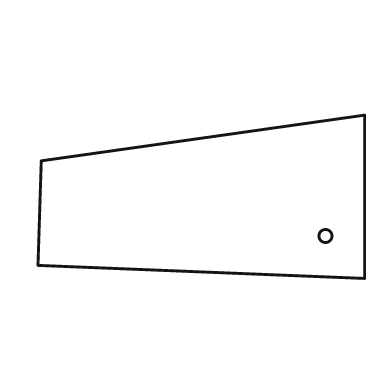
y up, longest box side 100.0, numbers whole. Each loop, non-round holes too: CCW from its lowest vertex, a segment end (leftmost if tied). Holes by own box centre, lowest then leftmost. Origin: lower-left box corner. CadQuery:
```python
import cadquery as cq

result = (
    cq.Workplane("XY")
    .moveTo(100.0, 0.0)
    .lineTo(100.0, 50.0)
    .lineTo(1.0, 36.0)
    .lineTo(0.0, 4.0)
    .close()
    .moveTo(88.0, 13.0)
    .circle(2.0)
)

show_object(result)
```